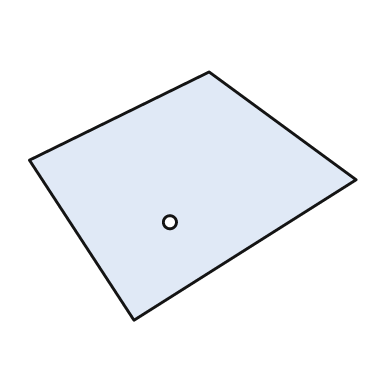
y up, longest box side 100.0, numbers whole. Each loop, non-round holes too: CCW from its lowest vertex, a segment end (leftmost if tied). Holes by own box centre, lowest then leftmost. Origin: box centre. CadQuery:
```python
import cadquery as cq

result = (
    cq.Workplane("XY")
    .moveTo(-18.0, -38.0)
    .lineTo(50.0, 5.0)
    .lineTo(5.0, 38.0)
    .lineTo(-50.0, 11.0)
    .close()
    .moveTo(-7.0, -8.0)
    .circle(2.0)
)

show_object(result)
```